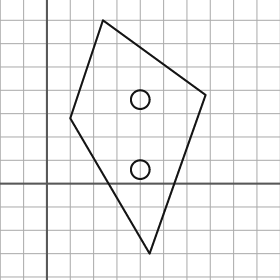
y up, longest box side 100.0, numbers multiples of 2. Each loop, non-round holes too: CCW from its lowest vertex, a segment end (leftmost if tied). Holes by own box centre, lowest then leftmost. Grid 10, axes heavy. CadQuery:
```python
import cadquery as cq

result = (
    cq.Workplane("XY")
    .moveTo(44.0, -30.0)
    .lineTo(68.0, 38.0)
    .lineTo(24.0, 70.0)
    .lineTo(10.0, 28.0)
    .close()
    .moveTo(40.0, 6.0)
    .circle(4.0)
    .moveTo(40.0, 36.0)
    .circle(4.0)
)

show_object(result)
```